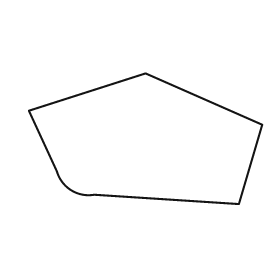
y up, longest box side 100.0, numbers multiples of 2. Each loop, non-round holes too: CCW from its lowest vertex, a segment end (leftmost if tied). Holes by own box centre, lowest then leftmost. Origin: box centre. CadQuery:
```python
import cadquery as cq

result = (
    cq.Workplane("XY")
    .moveTo(40.0, -28.0)
    .lineTo(50.0, 6.0)
    .lineTo(0.0, 28.0)
    .lineTo(-50.0, 12.0)
    .lineTo(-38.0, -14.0)
    .threePointArc((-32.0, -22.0), (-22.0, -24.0))
    .close()
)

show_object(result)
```